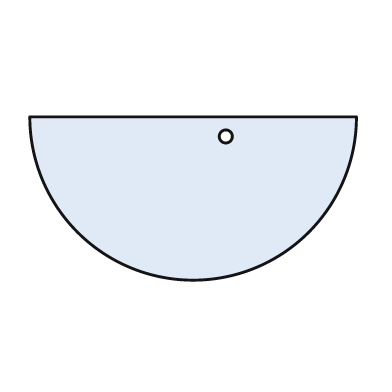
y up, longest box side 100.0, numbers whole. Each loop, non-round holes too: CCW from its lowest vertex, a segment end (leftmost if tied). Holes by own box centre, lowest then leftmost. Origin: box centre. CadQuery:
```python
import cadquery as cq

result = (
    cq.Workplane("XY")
    .moveTo(-50.0, 25.0)
    .threePointArc((0.0, -25.0), (50.0, 25.0))
    .close()
    .moveTo(10.0, 19.0)
    .circle(2.0)
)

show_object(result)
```